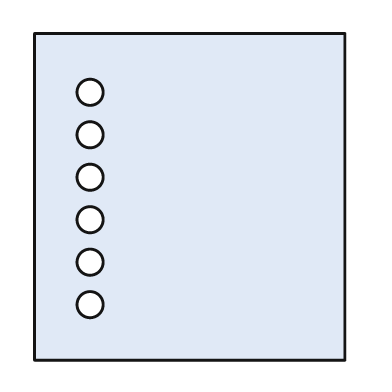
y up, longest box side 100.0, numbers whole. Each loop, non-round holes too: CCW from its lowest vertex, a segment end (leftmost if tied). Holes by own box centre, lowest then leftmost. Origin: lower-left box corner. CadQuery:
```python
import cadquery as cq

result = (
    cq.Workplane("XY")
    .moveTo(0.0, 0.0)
    .lineTo(95.0, 0.0)
    .lineTo(95.0, 100.0)
    .lineTo(0.0, 100.0)
    .close()
    .moveTo(17.0, 17.0)
    .circle(4.0)
    .moveTo(17.0, 30.0)
    .circle(4.0)
    .moveTo(17.0, 43.0)
    .circle(4.0)
    .moveTo(17.0, 56.0)
    .circle(4.0)
    .moveTo(17.0, 69.0)
    .circle(4.0)
    .moveTo(17.0, 82.0)
    .circle(4.0)
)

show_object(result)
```